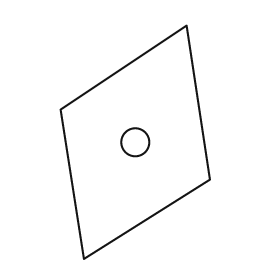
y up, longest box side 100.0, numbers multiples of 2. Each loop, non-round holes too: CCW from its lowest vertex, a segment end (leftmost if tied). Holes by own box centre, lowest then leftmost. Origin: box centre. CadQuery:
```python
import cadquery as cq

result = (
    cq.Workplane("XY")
    .moveTo(-22.0, -50.0)
    .lineTo(32.0, -16.0)
    .lineTo(22.0, 50.0)
    .lineTo(-32.0, 14.0)
    .close()
    .moveTo(0.0, 0.0)
    .circle(6.0)
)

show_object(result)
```